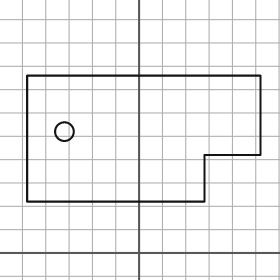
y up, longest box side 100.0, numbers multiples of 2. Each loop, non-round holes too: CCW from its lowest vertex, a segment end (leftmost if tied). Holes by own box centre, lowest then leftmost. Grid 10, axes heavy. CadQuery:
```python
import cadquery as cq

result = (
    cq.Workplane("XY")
    .moveTo(-48.0, 22.0)
    .lineTo(28.0, 22.0)
    .lineTo(28.0, 42.0)
    .lineTo(52.0, 42.0)
    .lineTo(52.0, 76.0)
    .lineTo(-48.0, 76.0)
    .close()
    .moveTo(-32.0, 52.0)
    .circle(4.0)
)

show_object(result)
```